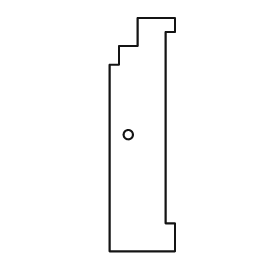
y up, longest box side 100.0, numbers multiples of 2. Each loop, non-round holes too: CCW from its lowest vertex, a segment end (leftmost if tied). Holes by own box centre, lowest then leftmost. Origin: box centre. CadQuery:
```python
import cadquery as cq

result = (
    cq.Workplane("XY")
    .moveTo(-14.0, -50.0)
    .lineTo(14.0, -50.0)
    .lineTo(14.0, -38.0)
    .lineTo(10.0, -38.0)
    .lineTo(10.0, 44.0)
    .lineTo(14.0, 44.0)
    .lineTo(14.0, 50.0)
    .lineTo(-2.0, 50.0)
    .lineTo(-2.0, 38.0)
    .lineTo(-10.0, 38.0)
    .lineTo(-10.0, 30.0)
    .lineTo(-14.0, 30.0)
    .close()
    .moveTo(-6.0, 0.0)
    .circle(2.0)
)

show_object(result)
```